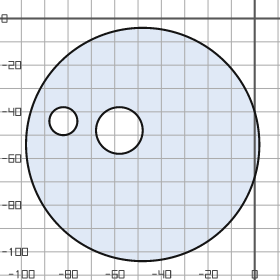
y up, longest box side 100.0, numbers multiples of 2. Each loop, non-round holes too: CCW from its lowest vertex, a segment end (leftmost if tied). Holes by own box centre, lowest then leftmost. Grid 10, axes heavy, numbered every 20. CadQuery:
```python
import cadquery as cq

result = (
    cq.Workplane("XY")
    .moveTo(-48.0, -54.0)
    .circle(50.0)
    .moveTo(-58.0, -48.0)
    .circle(10.0)
    .moveTo(-82.0, -44.0)
    .circle(6.0)
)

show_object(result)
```